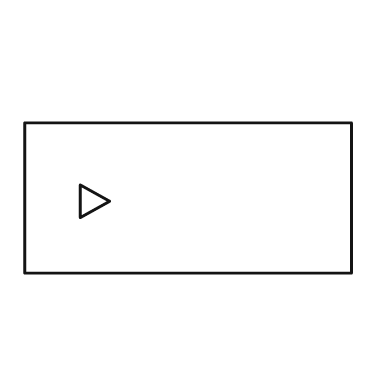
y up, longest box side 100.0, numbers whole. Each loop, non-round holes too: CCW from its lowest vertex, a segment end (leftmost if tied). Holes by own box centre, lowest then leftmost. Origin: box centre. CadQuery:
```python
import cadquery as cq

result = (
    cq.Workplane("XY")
    .moveTo(-50.0, -23.0)
    .lineTo(50.0, -23.0)
    .lineTo(50.0, 23.0)
    .lineTo(-50.0, 23.0)
    .close()
    .moveTo(-33.0, -6.0)
    .lineTo(-24.0, -1.0)
    .lineTo(-33.0, 4.0)
    .close()
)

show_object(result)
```